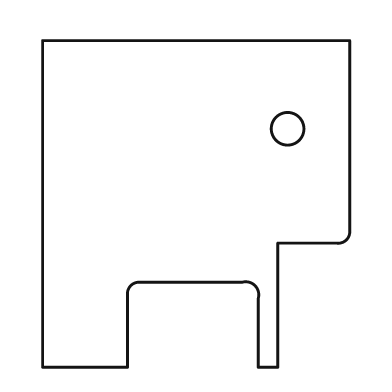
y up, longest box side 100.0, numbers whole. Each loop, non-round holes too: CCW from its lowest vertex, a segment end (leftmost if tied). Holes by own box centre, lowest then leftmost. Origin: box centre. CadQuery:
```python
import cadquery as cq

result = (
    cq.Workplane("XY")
    .moveTo(-47.0, -50.0)
    .lineTo(-21.0, -50.0)
    .lineTo(-21.0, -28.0)
    .threePointArc((-20.0, -25.0), (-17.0, -24.0))
    .lineTo(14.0, -24.0)
    .threePointArc((18.0, -25.0), (19.0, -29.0))
    .lineTo(19.0, -50.0)
    .lineTo(25.0, -50.0)
    .lineTo(25.0, -12.0)
    .lineTo(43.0, -12.0)
    .threePointArc((46.0, -11.0), (47.0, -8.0))
    .lineTo(47.0, 50.0)
    .lineTo(-47.0, 50.0)
    .close()
    .moveTo(28.0, 23.0)
    .circle(5.0)
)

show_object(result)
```